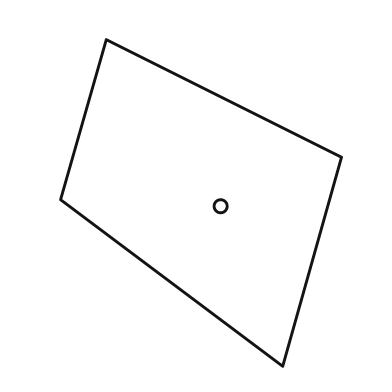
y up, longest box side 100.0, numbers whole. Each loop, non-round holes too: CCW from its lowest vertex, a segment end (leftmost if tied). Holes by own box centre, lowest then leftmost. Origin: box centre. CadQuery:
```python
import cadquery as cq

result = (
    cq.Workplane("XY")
    .moveTo(25.0, -50.0)
    .lineTo(43.0, 14.0)
    .lineTo(-29.0, 50.0)
    .lineTo(-43.0, 1.0)
    .close()
    .moveTo(6.0, -1.0)
    .circle(2.0)
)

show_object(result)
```